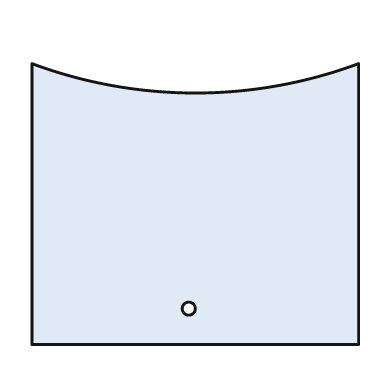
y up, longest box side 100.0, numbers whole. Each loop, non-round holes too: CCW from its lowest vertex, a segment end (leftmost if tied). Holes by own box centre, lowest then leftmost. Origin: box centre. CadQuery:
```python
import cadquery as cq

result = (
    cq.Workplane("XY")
    .moveTo(-50.0, -43.0)
    .lineTo(50.0, -43.0)
    .lineTo(50.0, 43.0)
    .threePointArc((0.0, 34.0), (-50.0, 43.0))
    .close()
    .moveTo(-2.0, -32.0)
    .circle(2.0)
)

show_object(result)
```